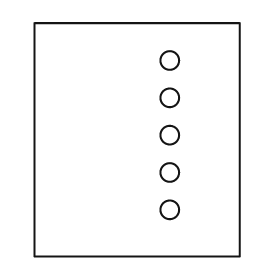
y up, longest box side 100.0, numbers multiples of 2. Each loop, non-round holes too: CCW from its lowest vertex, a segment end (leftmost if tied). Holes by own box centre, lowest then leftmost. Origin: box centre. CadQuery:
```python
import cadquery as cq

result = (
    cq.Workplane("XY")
    .moveTo(-44.0, -50.0)
    .lineTo(44.0, -50.0)
    .lineTo(44.0, 50.0)
    .lineTo(-44.0, 50.0)
    .close()
    .moveTo(14.0, -30.0)
    .circle(4.0)
    .moveTo(14.0, -14.0)
    .circle(4.0)
    .moveTo(14.0, 2.0)
    .circle(4.0)
    .moveTo(14.0, 18.0)
    .circle(4.0)
    .moveTo(14.0, 34.0)
    .circle(4.0)
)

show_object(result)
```